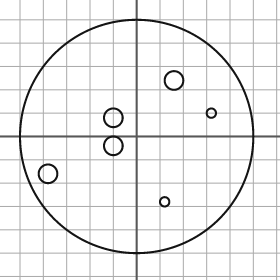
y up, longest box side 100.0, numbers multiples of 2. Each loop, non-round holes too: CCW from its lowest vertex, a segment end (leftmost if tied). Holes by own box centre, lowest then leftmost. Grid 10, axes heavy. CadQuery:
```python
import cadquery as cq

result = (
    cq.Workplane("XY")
    .moveTo(0.0, 0.0)
    .circle(50.0)
    .moveTo(12.0, -28.0)
    .circle(2.0)
    .moveTo(-38.0, -16.0)
    .circle(4.0)
    .moveTo(-10.0, -4.0)
    .circle(4.0)
    .moveTo(-10.0, 8.0)
    .circle(4.0)
    .moveTo(32.0, 10.0)
    .circle(2.0)
    .moveTo(16.0, 24.0)
    .circle(4.0)
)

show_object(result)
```